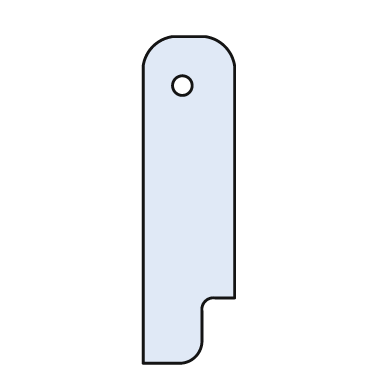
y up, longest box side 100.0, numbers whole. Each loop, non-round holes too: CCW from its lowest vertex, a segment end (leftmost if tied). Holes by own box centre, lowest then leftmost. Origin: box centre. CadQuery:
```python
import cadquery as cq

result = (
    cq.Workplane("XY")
    .moveTo(-14.0, -50.0)
    .lineTo(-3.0, -50.0)
    .threePointArc((2.0, -48.0), (4.0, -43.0))
    .lineTo(4.0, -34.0)
    .threePointArc((5.0, -31.0), (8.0, -30.0))
    .lineTo(14.0, -30.0)
    .lineTo(14.0, 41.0)
    .threePointArc((11.0, 47.0), (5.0, 50.0))
    .lineTo(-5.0, 50.0)
    .threePointArc((-11.0, 47.0), (-14.0, 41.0))
    .close()
    .moveTo(-2.0, 35.0)
    .circle(3.0)
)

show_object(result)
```